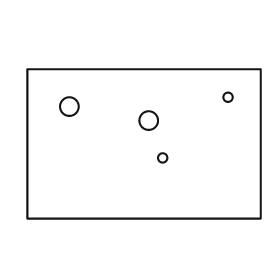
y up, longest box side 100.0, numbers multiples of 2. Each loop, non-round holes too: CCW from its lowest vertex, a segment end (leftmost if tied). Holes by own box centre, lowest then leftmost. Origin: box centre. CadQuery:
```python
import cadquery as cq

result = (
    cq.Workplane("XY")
    .moveTo(-50.0, -32.0)
    .lineTo(50.0, -32.0)
    .lineTo(50.0, 32.0)
    .lineTo(-50.0, 32.0)
    .close()
    .moveTo(8.0, -6.0)
    .circle(2.0)
    .moveTo(2.0, 10.0)
    .circle(4.0)
    .moveTo(-32.0, 16.0)
    .circle(4.0)
    .moveTo(36.0, 20.0)
    .circle(2.0)
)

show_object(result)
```